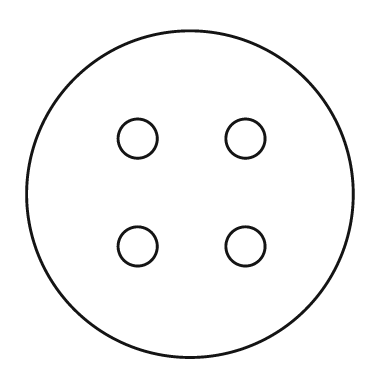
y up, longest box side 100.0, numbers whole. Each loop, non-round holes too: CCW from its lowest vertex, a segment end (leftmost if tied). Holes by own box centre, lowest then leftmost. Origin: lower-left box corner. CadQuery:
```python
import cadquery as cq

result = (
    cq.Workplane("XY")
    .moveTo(50.0, 50.0)
    .circle(50.0)
    .moveTo(34.0, 34.0)
    .circle(6.0)
    .moveTo(67.0, 34.0)
    .circle(6.0)
    .moveTo(34.0, 67.0)
    .circle(6.0)
    .moveTo(67.0, 67.0)
    .circle(6.0)
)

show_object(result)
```